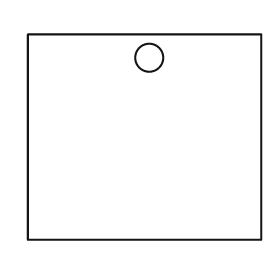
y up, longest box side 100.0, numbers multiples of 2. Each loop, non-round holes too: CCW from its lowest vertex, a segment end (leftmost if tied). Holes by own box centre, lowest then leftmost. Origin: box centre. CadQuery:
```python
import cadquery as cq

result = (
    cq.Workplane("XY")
    .moveTo(-50.0, -44.0)
    .lineTo(50.0, -44.0)
    .lineTo(50.0, 44.0)
    .lineTo(-50.0, 44.0)
    .close()
    .moveTo(2.0, 34.0)
    .circle(6.0)
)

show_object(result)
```